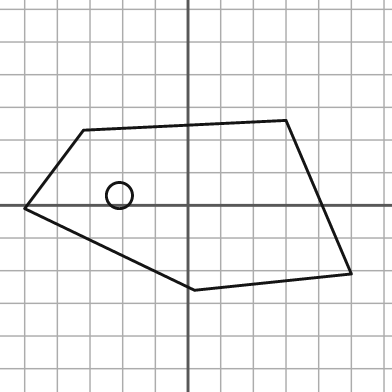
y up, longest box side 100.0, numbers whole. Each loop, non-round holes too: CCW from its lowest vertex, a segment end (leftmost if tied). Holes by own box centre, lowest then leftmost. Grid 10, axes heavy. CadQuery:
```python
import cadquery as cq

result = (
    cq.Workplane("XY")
    .moveTo(2.0, -26.0)
    .lineTo(50.0, -21.0)
    .lineTo(30.0, 26.0)
    .lineTo(-32.0, 23.0)
    .lineTo(-50.0, -1.0)
    .close()
    .moveTo(-21.0, 3.0)
    .circle(4.0)
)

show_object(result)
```